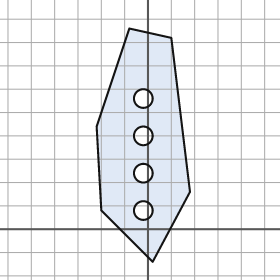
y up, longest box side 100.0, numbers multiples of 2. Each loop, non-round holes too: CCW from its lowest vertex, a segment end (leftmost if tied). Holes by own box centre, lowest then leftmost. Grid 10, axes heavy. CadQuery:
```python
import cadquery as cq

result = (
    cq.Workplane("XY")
    .moveTo(2.0, -14.0)
    .lineTo(18.0, 16.0)
    .lineTo(10.0, 82.0)
    .lineTo(-8.0, 86.0)
    .lineTo(-22.0, 44.0)
    .lineTo(-20.0, 8.0)
    .close()
    .moveTo(-2.0, 8.0)
    .circle(4.0)
    .moveTo(-2.0, 24.0)
    .circle(4.0)
    .moveTo(-2.0, 40.0)
    .circle(4.0)
    .moveTo(-2.0, 56.0)
    .circle(4.0)
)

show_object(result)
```